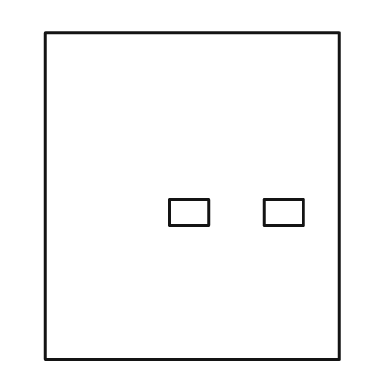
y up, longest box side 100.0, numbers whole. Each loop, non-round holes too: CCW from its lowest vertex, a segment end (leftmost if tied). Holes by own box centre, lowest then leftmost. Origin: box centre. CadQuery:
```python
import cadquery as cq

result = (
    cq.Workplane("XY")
    .moveTo(-45.0, -50.0)
    .lineTo(45.0, -50.0)
    .lineTo(45.0, 50.0)
    .lineTo(-45.0, 50.0)
    .close()
    .moveTo(-7.0, -9.0)
    .lineTo(5.0, -9.0)
    .lineTo(5.0, -1.0)
    .lineTo(-7.0, -1.0)
    .close()
    .moveTo(22.0, -9.0)
    .lineTo(34.0, -9.0)
    .lineTo(34.0, -1.0)
    .lineTo(22.0, -1.0)
    .close()
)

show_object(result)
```